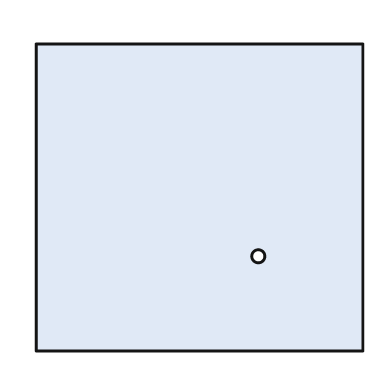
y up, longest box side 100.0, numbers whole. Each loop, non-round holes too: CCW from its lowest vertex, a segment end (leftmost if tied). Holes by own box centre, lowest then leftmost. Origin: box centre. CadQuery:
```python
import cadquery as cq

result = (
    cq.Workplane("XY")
    .moveTo(-50.0, -47.0)
    .lineTo(50.0, -47.0)
    .lineTo(50.0, 47.0)
    .lineTo(-50.0, 47.0)
    .close()
    .moveTo(18.0, -18.0)
    .circle(2.0)
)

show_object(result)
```